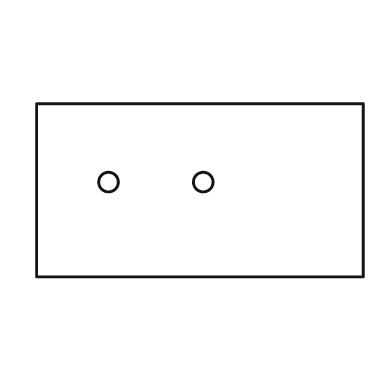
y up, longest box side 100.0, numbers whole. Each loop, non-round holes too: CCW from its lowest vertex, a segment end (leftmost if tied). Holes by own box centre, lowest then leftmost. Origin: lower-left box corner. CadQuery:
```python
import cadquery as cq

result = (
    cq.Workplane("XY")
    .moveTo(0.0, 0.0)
    .lineTo(100.0, 0.0)
    .lineTo(100.0, 53.0)
    .lineTo(0.0, 53.0)
    .close()
    .moveTo(22.0, 29.0)
    .circle(3.0)
    .moveTo(51.0, 29.0)
    .circle(3.0)
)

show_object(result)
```